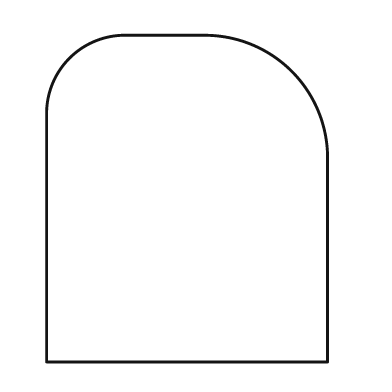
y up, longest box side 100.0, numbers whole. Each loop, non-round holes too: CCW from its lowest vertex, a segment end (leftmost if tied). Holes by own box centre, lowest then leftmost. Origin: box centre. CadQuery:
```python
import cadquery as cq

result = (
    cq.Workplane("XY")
    .moveTo(-43.0, -50.0)
    .lineTo(43.0, -50.0)
    .lineTo(43.0, 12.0)
    .threePointArc((32.0, 39.0), (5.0, 50.0))
    .lineTo(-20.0, 50.0)
    .threePointArc((-36.0, 43.0), (-43.0, 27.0))
    .close()
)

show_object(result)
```